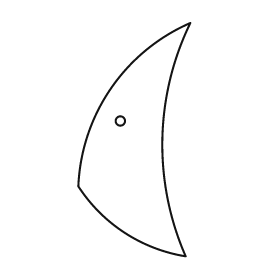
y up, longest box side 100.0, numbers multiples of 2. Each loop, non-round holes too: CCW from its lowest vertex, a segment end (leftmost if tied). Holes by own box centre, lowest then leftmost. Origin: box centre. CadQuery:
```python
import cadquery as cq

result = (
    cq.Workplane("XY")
    .moveTo(22.0, -50.0)
    .threePointArc((12.0, 0.0), (24.0, 50.0))
    .threePointArc((-10.0, 22.0), (-24.0, -20.0))
    .threePointArc((-4.0, -40.0), (22.0, -50.0))
    .close()
    .moveTo(-6.0, 8.0)
    .circle(2.0)
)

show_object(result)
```